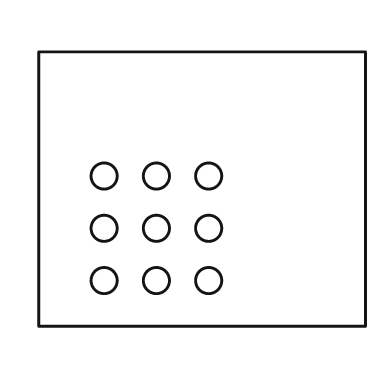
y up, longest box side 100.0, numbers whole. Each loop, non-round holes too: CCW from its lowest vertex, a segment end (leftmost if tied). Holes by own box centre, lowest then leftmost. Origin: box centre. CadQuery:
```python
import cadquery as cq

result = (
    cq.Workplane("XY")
    .moveTo(-50.0, -42.0)
    .lineTo(50.0, -42.0)
    .lineTo(50.0, 42.0)
    .lineTo(-50.0, 42.0)
    .close()
    .moveTo(-30.0, -28.0)
    .circle(4.0)
    .moveTo(-14.0, -28.0)
    .circle(4.0)
    .moveTo(2.0, -28.0)
    .circle(4.0)
    .moveTo(-30.0, -12.0)
    .circle(4.0)
    .moveTo(-14.0, -12.0)
    .circle(4.0)
    .moveTo(2.0, -12.0)
    .circle(4.0)
    .moveTo(-30.0, 4.0)
    .circle(4.0)
    .moveTo(-14.0, 4.0)
    .circle(4.0)
    .moveTo(2.0, 4.0)
    .circle(4.0)
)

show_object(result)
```